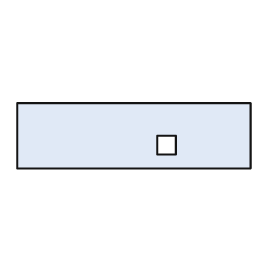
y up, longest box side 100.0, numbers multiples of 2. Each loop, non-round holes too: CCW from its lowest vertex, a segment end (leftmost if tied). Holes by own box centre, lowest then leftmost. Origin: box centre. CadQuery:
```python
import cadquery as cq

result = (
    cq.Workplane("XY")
    .moveTo(-50.0, -14.0)
    .lineTo(50.0, -14.0)
    .lineTo(50.0, 14.0)
    .lineTo(-50.0, 14.0)
    .close()
    .moveTo(10.0, -8.0)
    .lineTo(18.0, -8.0)
    .lineTo(18.0, 0.0)
    .lineTo(10.0, 0.0)
    .close()
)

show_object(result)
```